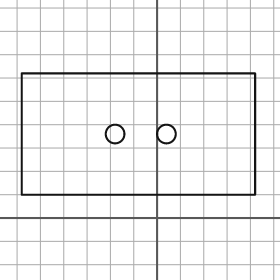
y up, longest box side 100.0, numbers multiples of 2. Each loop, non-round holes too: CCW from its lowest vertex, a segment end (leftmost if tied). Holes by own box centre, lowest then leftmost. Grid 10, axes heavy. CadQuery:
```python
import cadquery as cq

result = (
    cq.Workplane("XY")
    .moveTo(-58.0, 10.0)
    .lineTo(42.0, 10.0)
    .lineTo(42.0, 62.0)
    .lineTo(-58.0, 62.0)
    .close()
    .moveTo(-18.0, 36.0)
    .circle(4.0)
    .moveTo(4.0, 36.0)
    .circle(4.0)
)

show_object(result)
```